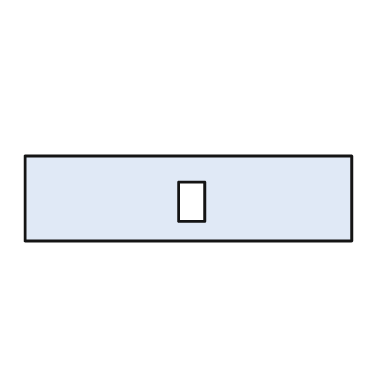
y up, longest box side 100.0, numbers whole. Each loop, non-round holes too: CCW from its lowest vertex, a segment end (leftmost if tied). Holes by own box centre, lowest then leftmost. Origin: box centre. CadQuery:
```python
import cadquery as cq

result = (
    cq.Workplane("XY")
    .moveTo(-50.0, -13.0)
    .lineTo(50.0, -13.0)
    .lineTo(50.0, 13.0)
    .lineTo(-50.0, 13.0)
    .close()
    .moveTo(-3.0, -7.0)
    .lineTo(5.0, -7.0)
    .lineTo(5.0, 5.0)
    .lineTo(-3.0, 5.0)
    .close()
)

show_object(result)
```